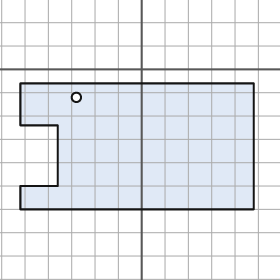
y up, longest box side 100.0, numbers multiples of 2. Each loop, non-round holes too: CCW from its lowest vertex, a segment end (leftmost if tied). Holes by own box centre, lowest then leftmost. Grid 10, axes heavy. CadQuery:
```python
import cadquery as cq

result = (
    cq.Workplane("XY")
    .moveTo(-52.0, -60.0)
    .lineTo(48.0, -60.0)
    .lineTo(48.0, -6.0)
    .lineTo(-52.0, -6.0)
    .lineTo(-52.0, -24.0)
    .lineTo(-36.0, -24.0)
    .lineTo(-36.0, -50.0)
    .lineTo(-52.0, -50.0)
    .close()
    .moveTo(-28.0, -12.0)
    .circle(2.0)
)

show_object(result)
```